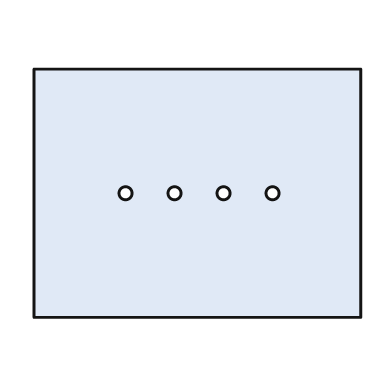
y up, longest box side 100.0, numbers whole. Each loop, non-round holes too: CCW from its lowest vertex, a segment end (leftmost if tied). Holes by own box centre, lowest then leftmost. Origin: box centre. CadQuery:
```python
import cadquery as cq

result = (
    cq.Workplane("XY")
    .moveTo(-50.0, -38.0)
    .lineTo(50.0, -38.0)
    .lineTo(50.0, 38.0)
    .lineTo(-50.0, 38.0)
    .close()
    .moveTo(-22.0, 0.0)
    .circle(2.0)
    .moveTo(-7.0, 0.0)
    .circle(2.0)
    .moveTo(8.0, 0.0)
    .circle(2.0)
    .moveTo(23.0, 0.0)
    .circle(2.0)
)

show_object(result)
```